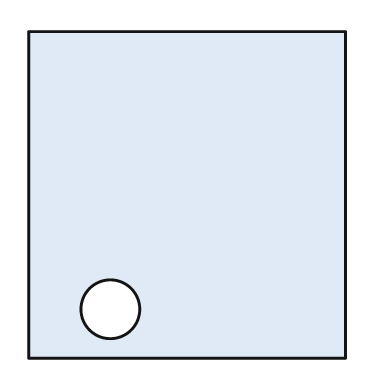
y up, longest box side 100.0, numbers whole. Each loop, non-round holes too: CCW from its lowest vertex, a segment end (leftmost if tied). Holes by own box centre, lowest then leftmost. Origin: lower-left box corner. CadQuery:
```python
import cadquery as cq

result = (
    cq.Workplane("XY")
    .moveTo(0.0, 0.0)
    .lineTo(97.0, 0.0)
    .lineTo(97.0, 100.0)
    .lineTo(0.0, 100.0)
    .close()
    .moveTo(25.0, 15.0)
    .circle(9.0)
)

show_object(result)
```